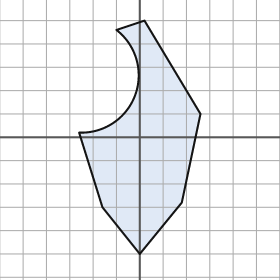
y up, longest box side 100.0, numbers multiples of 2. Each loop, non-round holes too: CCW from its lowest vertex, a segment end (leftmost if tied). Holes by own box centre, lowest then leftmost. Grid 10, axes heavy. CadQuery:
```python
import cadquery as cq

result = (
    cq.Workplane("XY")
    .moveTo(0.0, -50.0)
    .lineTo(18.0, -28.0)
    .lineTo(26.0, 10.0)
    .lineTo(2.0, 50.0)
    .lineTo(-10.0, 46.0)
    .threePointArc((-2.0, 18.0), (-26.0, 2.0))
    .lineTo(-16.0, -30.0)
    .close()
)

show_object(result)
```